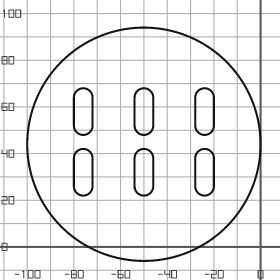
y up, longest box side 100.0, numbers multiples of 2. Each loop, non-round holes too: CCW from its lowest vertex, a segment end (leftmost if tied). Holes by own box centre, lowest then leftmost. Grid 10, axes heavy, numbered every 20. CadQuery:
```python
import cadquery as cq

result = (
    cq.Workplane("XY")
    .moveTo(-50.0, 44.0)
    .circle(50.0)
    .moveTo(-80.0, 26.0)
    .threePointArc((-76.0, 22.0), (-72.0, 26.0))
    .lineTo(-72.0, 38.0)
    .threePointArc((-76.0, 42.0), (-80.0, 38.0))
    .close()
    .moveTo(-54.0, 26.0)
    .threePointArc((-50.0, 22.0), (-46.0, 26.0))
    .lineTo(-46.0, 38.0)
    .threePointArc((-50.0, 42.0), (-54.0, 38.0))
    .close()
    .moveTo(-28.0, 26.0)
    .threePointArc((-24.0, 22.0), (-20.0, 26.0))
    .lineTo(-20.0, 38.0)
    .threePointArc((-24.0, 42.0), (-28.0, 38.0))
    .close()
    .moveTo(-80.0, 52.0)
    .threePointArc((-76.0, 48.0), (-72.0, 52.0))
    .lineTo(-72.0, 64.0)
    .threePointArc((-76.0, 68.0), (-80.0, 64.0))
    .close()
    .moveTo(-54.0, 52.0)
    .threePointArc((-50.0, 48.0), (-46.0, 52.0))
    .lineTo(-46.0, 64.0)
    .threePointArc((-50.0, 68.0), (-54.0, 64.0))
    .close()
    .moveTo(-28.0, 52.0)
    .threePointArc((-24.0, 48.0), (-20.0, 52.0))
    .lineTo(-20.0, 64.0)
    .threePointArc((-24.0, 68.0), (-28.0, 64.0))
    .close()
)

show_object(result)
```